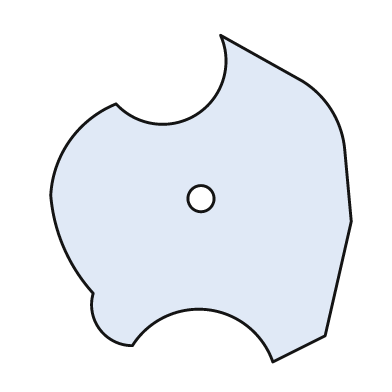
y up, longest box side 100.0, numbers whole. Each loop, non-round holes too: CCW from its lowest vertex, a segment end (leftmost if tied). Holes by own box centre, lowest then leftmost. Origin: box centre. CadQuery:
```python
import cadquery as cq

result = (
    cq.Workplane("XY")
    .moveTo(22.0, -50.0)
    .lineTo(38.0, -42.0)
    .lineTo(46.0, -7.0)
    .lineTo(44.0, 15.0)
    .threePointArc((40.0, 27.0), (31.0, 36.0))
    .lineTo(6.0, 50.0)
    .threePointArc((-1.0, 26.0), (-26.0, 29.0))
    .threePointArc((-40.0, 18.0), (-46.0, 1.0))
    .threePointArc((-42.0, -15.0), (-33.0, -29.0))
    .threePointArc((-31.0, -40.0), (-21.0, -45.0))
    .threePointArc((2.0, -34.0), (22.0, -50.0))
    .close()
    .moveTo(0.0, 0.0)
    .circle(4.0)
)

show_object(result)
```